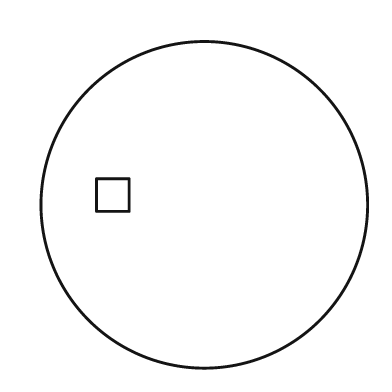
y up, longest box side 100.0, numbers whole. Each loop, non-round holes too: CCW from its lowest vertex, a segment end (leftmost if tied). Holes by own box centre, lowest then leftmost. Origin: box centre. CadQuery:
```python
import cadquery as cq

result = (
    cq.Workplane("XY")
    .moveTo(0.0, 0.0)
    .circle(50.0)
    .moveTo(-33.0, -2.0)
    .lineTo(-23.0, -2.0)
    .lineTo(-23.0, 8.0)
    .lineTo(-33.0, 8.0)
    .close()
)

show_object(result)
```